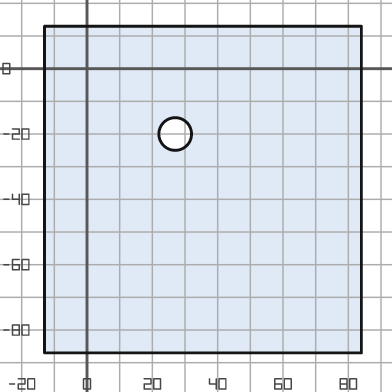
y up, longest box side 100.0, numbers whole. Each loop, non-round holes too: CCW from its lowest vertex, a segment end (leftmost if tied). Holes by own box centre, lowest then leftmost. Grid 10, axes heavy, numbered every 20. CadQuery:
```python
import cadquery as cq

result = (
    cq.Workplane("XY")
    .moveTo(-13.0, -87.0)
    .lineTo(84.0, -87.0)
    .lineTo(84.0, 13.0)
    .lineTo(-13.0, 13.0)
    .close()
    .moveTo(27.0, -20.0)
    .circle(5.0)
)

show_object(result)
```